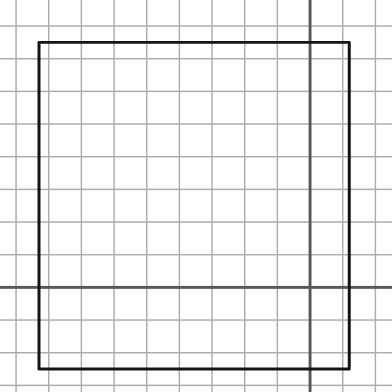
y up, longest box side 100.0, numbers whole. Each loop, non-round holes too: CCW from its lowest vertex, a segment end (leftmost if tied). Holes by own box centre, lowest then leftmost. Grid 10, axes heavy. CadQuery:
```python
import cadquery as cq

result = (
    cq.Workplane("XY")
    .moveTo(-83.0, -25.0)
    .lineTo(12.0, -25.0)
    .lineTo(12.0, 75.0)
    .lineTo(-83.0, 75.0)
    .close()
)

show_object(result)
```